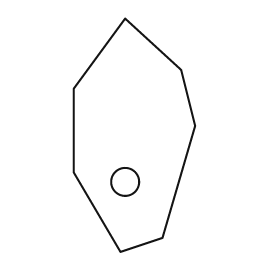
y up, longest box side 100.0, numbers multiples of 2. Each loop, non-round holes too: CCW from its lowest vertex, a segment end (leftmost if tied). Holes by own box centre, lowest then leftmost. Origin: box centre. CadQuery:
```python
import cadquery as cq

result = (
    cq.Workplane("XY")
    .moveTo(-6.0, -50.0)
    .lineTo(12.0, -44.0)
    .lineTo(26.0, 4.0)
    .lineTo(20.0, 28.0)
    .lineTo(-4.0, 50.0)
    .lineTo(-26.0, 20.0)
    .lineTo(-26.0, -16.0)
    .close()
    .moveTo(-4.0, -20.0)
    .circle(6.0)
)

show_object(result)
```